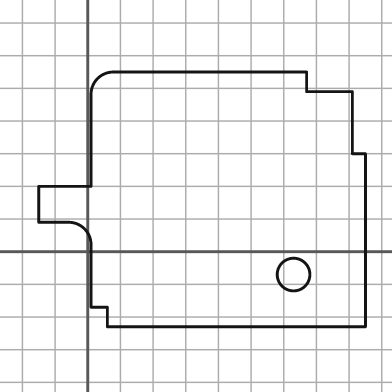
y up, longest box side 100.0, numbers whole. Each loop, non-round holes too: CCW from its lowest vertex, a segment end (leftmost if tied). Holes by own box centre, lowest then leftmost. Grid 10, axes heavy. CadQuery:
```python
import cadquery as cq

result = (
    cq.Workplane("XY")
    .moveTo(6.0, -23.0)
    .lineTo(85.0, -23.0)
    .lineTo(85.0, 30.0)
    .lineTo(81.0, 30.0)
    .lineTo(81.0, 49.0)
    .lineTo(67.0, 49.0)
    .lineTo(67.0, 55.0)
    .lineTo(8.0, 55.0)
    .threePointArc((3.0, 53.0), (1.0, 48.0))
    .lineTo(1.0, 20.0)
    .lineTo(-15.0, 20.0)
    .lineTo(-15.0, 9.0)
    .lineTo(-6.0, 9.0)
    .threePointArc((-1.0, 7.0), (1.0, 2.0))
    .lineTo(1.0, -17.0)
    .lineTo(6.0, -17.0)
    .close()
    .moveTo(63.0, -7.0)
    .circle(5.0)
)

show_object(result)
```